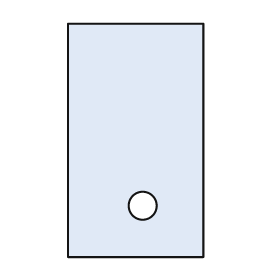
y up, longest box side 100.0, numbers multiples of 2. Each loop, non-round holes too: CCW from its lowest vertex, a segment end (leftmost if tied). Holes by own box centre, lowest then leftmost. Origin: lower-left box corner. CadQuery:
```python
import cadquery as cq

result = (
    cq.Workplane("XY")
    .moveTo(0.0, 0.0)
    .lineTo(58.0, 0.0)
    .lineTo(58.0, 100.0)
    .lineTo(0.0, 100.0)
    .close()
    .moveTo(32.0, 22.0)
    .circle(6.0)
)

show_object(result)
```